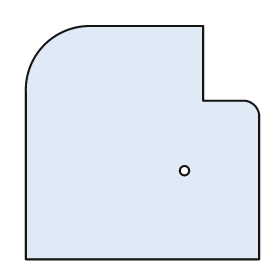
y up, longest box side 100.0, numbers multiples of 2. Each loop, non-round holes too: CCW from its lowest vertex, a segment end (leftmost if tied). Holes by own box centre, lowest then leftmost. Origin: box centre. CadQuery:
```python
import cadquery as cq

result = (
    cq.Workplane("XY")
    .moveTo(-50.0, -50.0)
    .lineTo(50.0, -50.0)
    .lineTo(50.0, 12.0)
    .threePointArc((48.0, 16.0), (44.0, 18.0))
    .lineTo(26.0, 18.0)
    .lineTo(26.0, 50.0)
    .lineTo(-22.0, 50.0)
    .threePointArc((-42.0, 42.0), (-50.0, 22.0))
    .close()
    .moveTo(18.0, -12.0)
    .circle(2.0)
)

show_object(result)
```